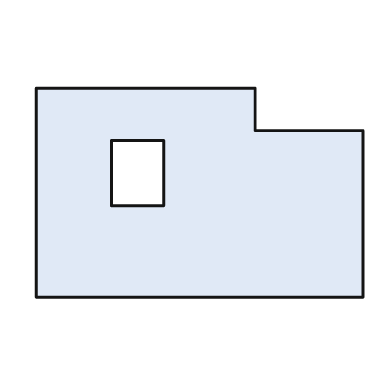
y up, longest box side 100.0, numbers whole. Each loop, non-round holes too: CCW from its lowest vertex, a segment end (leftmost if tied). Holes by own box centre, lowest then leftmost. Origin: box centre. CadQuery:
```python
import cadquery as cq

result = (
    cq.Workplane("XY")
    .moveTo(-50.0, -32.0)
    .lineTo(50.0, -32.0)
    .lineTo(50.0, 19.0)
    .lineTo(17.0, 19.0)
    .lineTo(17.0, 32.0)
    .lineTo(-50.0, 32.0)
    .close()
    .moveTo(-27.0, -4.0)
    .lineTo(-11.0, -4.0)
    .lineTo(-11.0, 16.0)
    .lineTo(-27.0, 16.0)
    .close()
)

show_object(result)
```